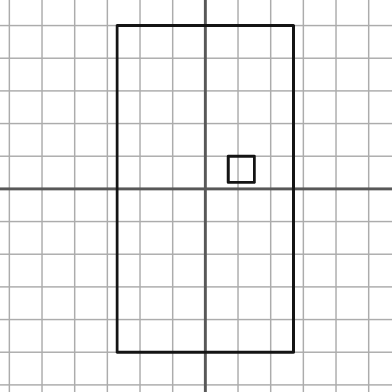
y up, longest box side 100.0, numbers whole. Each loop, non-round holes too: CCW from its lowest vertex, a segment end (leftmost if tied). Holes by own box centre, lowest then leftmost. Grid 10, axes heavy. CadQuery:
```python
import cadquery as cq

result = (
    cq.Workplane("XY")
    .moveTo(-27.0, -50.0)
    .lineTo(27.0, -50.0)
    .lineTo(27.0, 50.0)
    .lineTo(-27.0, 50.0)
    .close()
    .moveTo(7.0, 2.0)
    .lineTo(15.0, 2.0)
    .lineTo(15.0, 10.0)
    .lineTo(7.0, 10.0)
    .close()
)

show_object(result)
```